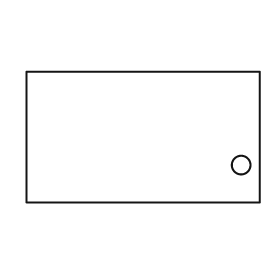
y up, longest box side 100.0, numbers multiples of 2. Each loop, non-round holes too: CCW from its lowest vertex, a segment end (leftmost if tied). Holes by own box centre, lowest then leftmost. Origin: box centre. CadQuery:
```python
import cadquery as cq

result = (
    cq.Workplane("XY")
    .moveTo(-50.0, -28.0)
    .lineTo(50.0, -28.0)
    .lineTo(50.0, 28.0)
    .lineTo(-50.0, 28.0)
    .close()
    .moveTo(42.0, -12.0)
    .circle(4.0)
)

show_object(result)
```